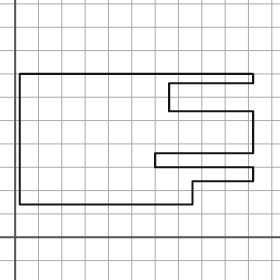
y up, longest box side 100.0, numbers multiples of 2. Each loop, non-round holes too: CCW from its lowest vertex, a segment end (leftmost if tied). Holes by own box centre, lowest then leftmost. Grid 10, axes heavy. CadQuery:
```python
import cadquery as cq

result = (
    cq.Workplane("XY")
    .moveTo(2.0, 14.0)
    .lineTo(76.0, 14.0)
    .lineTo(76.0, 24.0)
    .lineTo(102.0, 24.0)
    .lineTo(102.0, 30.0)
    .lineTo(60.0, 30.0)
    .lineTo(60.0, 36.0)
    .lineTo(102.0, 36.0)
    .lineTo(102.0, 54.0)
    .lineTo(66.0, 54.0)
    .lineTo(66.0, 66.0)
    .lineTo(102.0, 66.0)
    .lineTo(102.0, 70.0)
    .lineTo(2.0, 70.0)
    .close()
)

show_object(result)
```